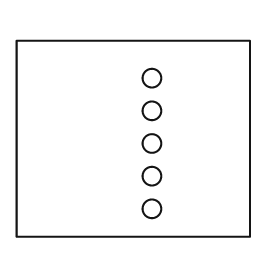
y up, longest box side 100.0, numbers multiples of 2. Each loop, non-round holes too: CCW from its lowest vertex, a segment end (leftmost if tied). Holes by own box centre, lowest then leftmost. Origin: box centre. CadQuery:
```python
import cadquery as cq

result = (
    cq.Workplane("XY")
    .moveTo(-50.0, -42.0)
    .lineTo(50.0, -42.0)
    .lineTo(50.0, 42.0)
    .lineTo(-50.0, 42.0)
    .close()
    .moveTo(8.0, -30.0)
    .circle(4.0)
    .moveTo(8.0, -16.0)
    .circle(4.0)
    .moveTo(8.0, -2.0)
    .circle(4.0)
    .moveTo(8.0, 12.0)
    .circle(4.0)
    .moveTo(8.0, 26.0)
    .circle(4.0)
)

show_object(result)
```